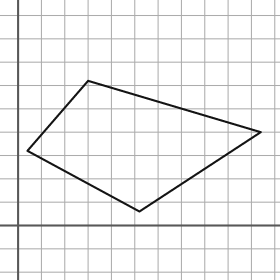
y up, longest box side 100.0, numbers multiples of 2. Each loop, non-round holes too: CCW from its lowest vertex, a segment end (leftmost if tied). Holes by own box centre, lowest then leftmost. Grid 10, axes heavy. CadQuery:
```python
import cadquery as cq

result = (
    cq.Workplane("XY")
    .moveTo(52.0, 6.0)
    .lineTo(104.0, 40.0)
    .lineTo(30.0, 62.0)
    .lineTo(4.0, 32.0)
    .close()
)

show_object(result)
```